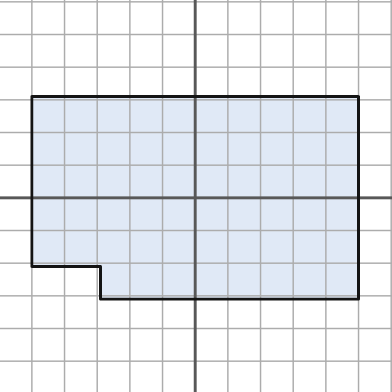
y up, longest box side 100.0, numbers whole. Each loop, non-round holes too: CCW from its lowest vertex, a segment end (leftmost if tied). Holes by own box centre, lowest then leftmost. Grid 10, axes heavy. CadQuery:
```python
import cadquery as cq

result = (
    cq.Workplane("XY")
    .moveTo(-29.0, -31.0)
    .lineTo(50.0, -31.0)
    .lineTo(50.0, 31.0)
    .lineTo(-50.0, 31.0)
    .lineTo(-50.0, -21.0)
    .lineTo(-29.0, -21.0)
    .close()
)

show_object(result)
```